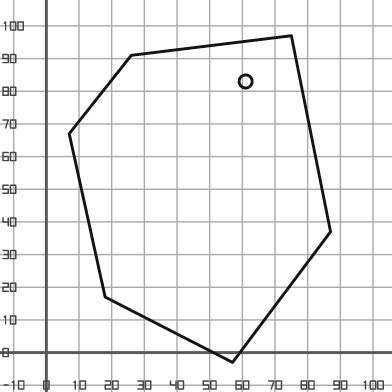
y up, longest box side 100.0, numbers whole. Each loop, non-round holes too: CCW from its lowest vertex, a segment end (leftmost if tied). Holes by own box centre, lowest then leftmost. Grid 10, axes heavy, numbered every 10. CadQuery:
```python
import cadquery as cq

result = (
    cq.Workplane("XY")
    .moveTo(57.0, -3.0)
    .lineTo(87.0, 37.0)
    .lineTo(75.0, 97.0)
    .lineTo(26.0, 91.0)
    .lineTo(7.0, 67.0)
    .lineTo(18.0, 17.0)
    .close()
    .moveTo(61.0, 83.0)
    .circle(2.0)
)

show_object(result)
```